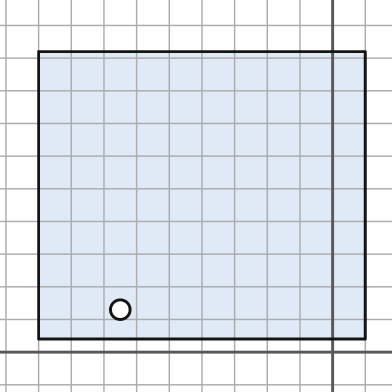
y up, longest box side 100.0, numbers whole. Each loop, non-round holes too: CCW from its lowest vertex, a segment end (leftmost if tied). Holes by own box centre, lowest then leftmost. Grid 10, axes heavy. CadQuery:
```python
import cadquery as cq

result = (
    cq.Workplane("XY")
    .moveTo(-90.0, 4.0)
    .lineTo(10.0, 4.0)
    .lineTo(10.0, 92.0)
    .lineTo(-90.0, 92.0)
    .close()
    .moveTo(-65.0, 13.0)
    .circle(3.0)
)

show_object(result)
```